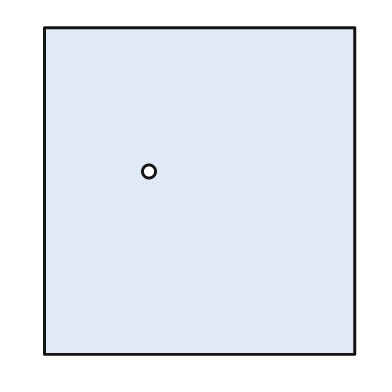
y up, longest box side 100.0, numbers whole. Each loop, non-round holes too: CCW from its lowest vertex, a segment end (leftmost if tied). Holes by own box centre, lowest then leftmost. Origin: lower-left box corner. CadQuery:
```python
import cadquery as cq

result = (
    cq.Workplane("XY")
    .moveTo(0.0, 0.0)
    .lineTo(95.0, 0.0)
    .lineTo(95.0, 100.0)
    .lineTo(0.0, 100.0)
    .close()
    .moveTo(32.0, 56.0)
    .circle(2.0)
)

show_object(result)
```